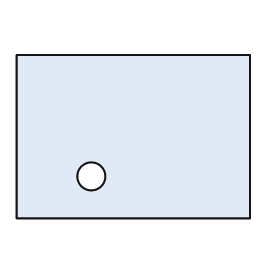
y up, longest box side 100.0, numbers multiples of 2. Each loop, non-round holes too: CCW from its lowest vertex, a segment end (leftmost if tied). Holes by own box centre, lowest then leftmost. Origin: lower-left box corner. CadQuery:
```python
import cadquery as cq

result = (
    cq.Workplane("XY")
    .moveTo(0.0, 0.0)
    .lineTo(100.0, 0.0)
    .lineTo(100.0, 70.0)
    .lineTo(0.0, 70.0)
    .close()
    .moveTo(32.0, 18.0)
    .circle(6.0)
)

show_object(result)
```